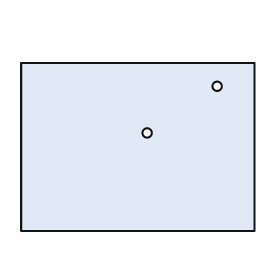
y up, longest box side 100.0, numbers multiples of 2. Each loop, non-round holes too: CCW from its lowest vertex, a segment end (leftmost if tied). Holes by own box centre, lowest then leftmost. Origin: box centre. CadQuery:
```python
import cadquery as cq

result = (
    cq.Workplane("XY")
    .moveTo(-50.0, -36.0)
    .lineTo(50.0, -36.0)
    .lineTo(50.0, 36.0)
    .lineTo(-50.0, 36.0)
    .close()
    .moveTo(4.0, 6.0)
    .circle(2.0)
    .moveTo(34.0, 26.0)
    .circle(2.0)
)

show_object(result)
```